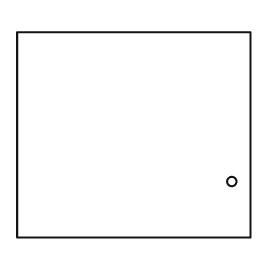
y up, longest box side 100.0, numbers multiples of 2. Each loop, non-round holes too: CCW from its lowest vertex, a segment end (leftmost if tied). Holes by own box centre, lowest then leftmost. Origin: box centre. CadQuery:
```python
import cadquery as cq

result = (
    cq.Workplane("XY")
    .moveTo(-50.0, -44.0)
    .lineTo(50.0, -44.0)
    .lineTo(50.0, 44.0)
    .lineTo(-50.0, 44.0)
    .close()
    .moveTo(42.0, -20.0)
    .circle(2.0)
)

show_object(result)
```